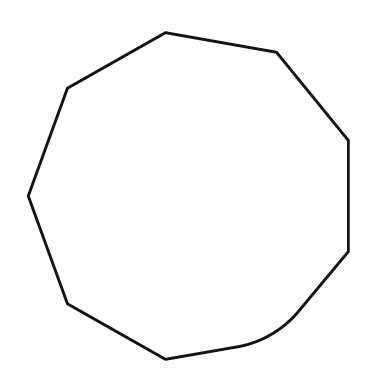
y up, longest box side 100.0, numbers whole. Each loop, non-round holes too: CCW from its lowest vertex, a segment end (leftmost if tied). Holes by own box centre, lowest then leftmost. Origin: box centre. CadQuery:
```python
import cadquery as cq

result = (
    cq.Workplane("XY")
    .moveTo(-7.0, -50.0)
    .lineTo(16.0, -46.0)
    .threePointArc((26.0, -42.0), (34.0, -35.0))
    .lineTo(49.0, -17.0)
    .lineTo(49.0, 17.0)
    .lineTo(27.0, 44.0)
    .lineTo(-7.0, 50.0)
    .lineTo(-37.0, 33.0)
    .lineTo(-49.0, 0.0)
    .lineTo(-37.0, -33.0)
    .close()
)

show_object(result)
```